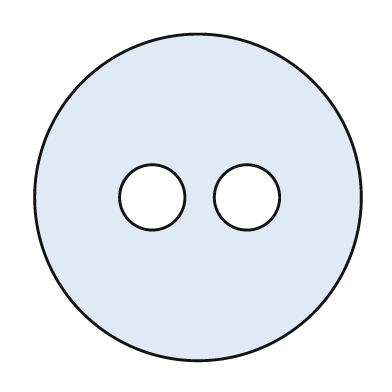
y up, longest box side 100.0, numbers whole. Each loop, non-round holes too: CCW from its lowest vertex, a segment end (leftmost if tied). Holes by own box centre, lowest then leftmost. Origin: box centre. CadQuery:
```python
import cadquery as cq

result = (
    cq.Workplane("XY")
    .moveTo(0.0, 0.0)
    .circle(50.0)
    .moveTo(-14.0, 0.0)
    .circle(10.0)
    .moveTo(15.0, 0.0)
    .circle(10.0)
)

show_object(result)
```